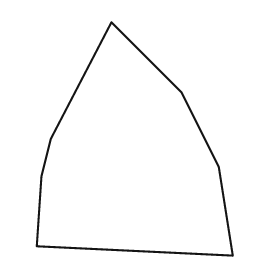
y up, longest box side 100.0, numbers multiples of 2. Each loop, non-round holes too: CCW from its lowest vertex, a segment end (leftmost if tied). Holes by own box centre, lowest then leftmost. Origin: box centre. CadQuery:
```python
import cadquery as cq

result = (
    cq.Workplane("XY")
    .moveTo(42.0, -50.0)
    .lineTo(36.0, -12.0)
    .lineTo(20.0, 20.0)
    .lineTo(-10.0, 50.0)
    .lineTo(-36.0, 0.0)
    .lineTo(-40.0, -16.0)
    .lineTo(-42.0, -46.0)
    .close()
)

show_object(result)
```